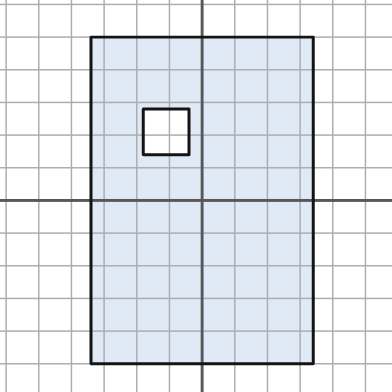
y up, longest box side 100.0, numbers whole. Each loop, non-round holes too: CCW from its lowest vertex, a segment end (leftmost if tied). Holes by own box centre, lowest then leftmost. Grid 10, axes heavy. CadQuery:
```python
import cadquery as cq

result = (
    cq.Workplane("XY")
    .moveTo(-34.0, -50.0)
    .lineTo(34.0, -50.0)
    .lineTo(34.0, 50.0)
    .lineTo(-34.0, 50.0)
    .close()
    .moveTo(-18.0, 14.0)
    .lineTo(-4.0, 14.0)
    .lineTo(-4.0, 28.0)
    .lineTo(-18.0, 28.0)
    .close()
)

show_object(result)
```